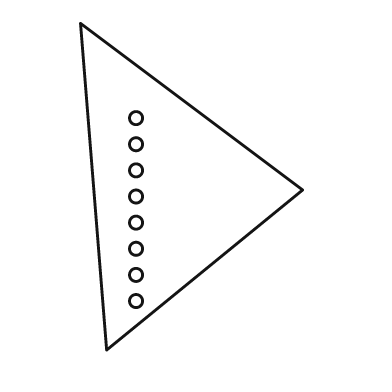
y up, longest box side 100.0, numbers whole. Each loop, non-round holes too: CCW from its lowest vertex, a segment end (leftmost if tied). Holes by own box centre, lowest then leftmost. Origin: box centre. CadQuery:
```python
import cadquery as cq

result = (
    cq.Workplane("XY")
    .moveTo(-26.0, -50.0)
    .lineTo(34.0, -1.0)
    .lineTo(-34.0, 50.0)
    .close()
    .moveTo(-17.0, -35.0)
    .circle(2.0)
    .moveTo(-17.0, -27.0)
    .circle(2.0)
    .moveTo(-17.0, -19.0)
    .circle(2.0)
    .moveTo(-17.0, -11.0)
    .circle(2.0)
    .moveTo(-17.0, -3.0)
    .circle(2.0)
    .moveTo(-17.0, 5.0)
    .circle(2.0)
    .moveTo(-17.0, 13.0)
    .circle(2.0)
    .moveTo(-17.0, 21.0)
    .circle(2.0)
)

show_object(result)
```